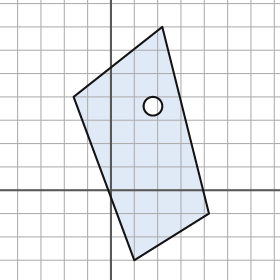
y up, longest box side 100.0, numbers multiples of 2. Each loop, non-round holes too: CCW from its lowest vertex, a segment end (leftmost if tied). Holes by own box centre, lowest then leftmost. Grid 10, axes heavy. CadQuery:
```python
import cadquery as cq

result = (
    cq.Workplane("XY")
    .moveTo(10.0, -30.0)
    .lineTo(42.0, -10.0)
    .lineTo(22.0, 70.0)
    .lineTo(-16.0, 40.0)
    .close()
    .moveTo(18.0, 36.0)
    .circle(4.0)
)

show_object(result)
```